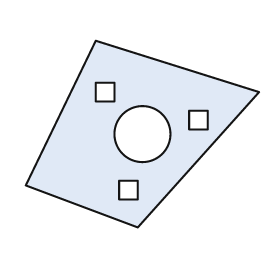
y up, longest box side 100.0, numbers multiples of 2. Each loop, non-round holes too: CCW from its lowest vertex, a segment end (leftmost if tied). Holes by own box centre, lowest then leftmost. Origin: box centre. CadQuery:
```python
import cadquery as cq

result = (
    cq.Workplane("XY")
    .moveTo(-2.0, -40.0)
    .lineTo(50.0, 18.0)
    .lineTo(-20.0, 40.0)
    .lineTo(-50.0, -22.0)
    .close()
    .moveTo(-10.0, -28.0)
    .lineTo(-2.0, -28.0)
    .lineTo(-2.0, -20.0)
    .lineTo(-10.0, -20.0)
    .close()
    .moveTo(0.0, 0.0)
    .circle(12.0)
    .moveTo(20.0, 2.0)
    .lineTo(28.0, 2.0)
    .lineTo(28.0, 10.0)
    .lineTo(20.0, 10.0)
    .close()
    .moveTo(-20.0, 14.0)
    .lineTo(-12.0, 14.0)
    .lineTo(-12.0, 22.0)
    .lineTo(-20.0, 22.0)
    .close()
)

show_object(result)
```